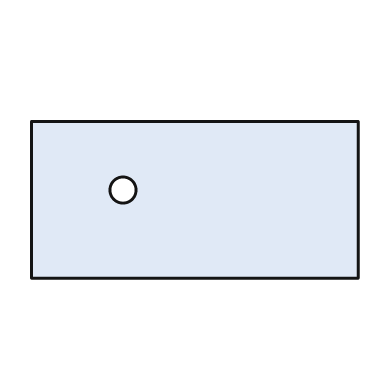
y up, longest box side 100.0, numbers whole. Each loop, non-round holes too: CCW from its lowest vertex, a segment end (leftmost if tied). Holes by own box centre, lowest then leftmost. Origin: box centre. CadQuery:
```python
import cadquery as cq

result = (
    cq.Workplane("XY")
    .moveTo(-50.0, -24.0)
    .lineTo(50.0, -24.0)
    .lineTo(50.0, 24.0)
    .lineTo(-50.0, 24.0)
    .close()
    .moveTo(-22.0, 3.0)
    .circle(4.0)
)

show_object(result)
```